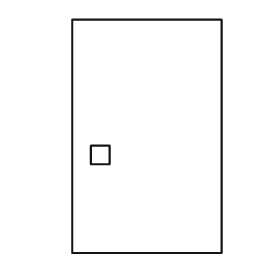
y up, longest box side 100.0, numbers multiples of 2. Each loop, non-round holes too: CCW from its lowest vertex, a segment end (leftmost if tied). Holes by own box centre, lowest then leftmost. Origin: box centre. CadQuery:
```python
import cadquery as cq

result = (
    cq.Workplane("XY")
    .moveTo(-32.0, -50.0)
    .lineTo(32.0, -50.0)
    .lineTo(32.0, 50.0)
    .lineTo(-32.0, 50.0)
    .close()
    .moveTo(-24.0, -12.0)
    .lineTo(-16.0, -12.0)
    .lineTo(-16.0, -4.0)
    .lineTo(-24.0, -4.0)
    .close()
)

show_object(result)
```